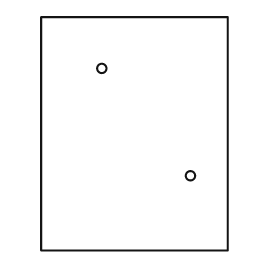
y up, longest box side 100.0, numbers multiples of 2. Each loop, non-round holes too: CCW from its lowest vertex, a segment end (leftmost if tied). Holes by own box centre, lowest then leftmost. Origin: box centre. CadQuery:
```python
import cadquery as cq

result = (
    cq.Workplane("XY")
    .moveTo(-40.0, -50.0)
    .lineTo(40.0, -50.0)
    .lineTo(40.0, 50.0)
    .lineTo(-40.0, 50.0)
    .close()
    .moveTo(24.0, -18.0)
    .circle(2.0)
    .moveTo(-14.0, 28.0)
    .circle(2.0)
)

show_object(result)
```